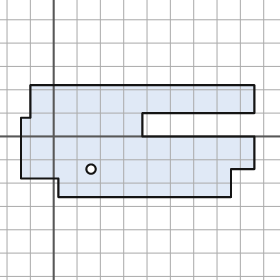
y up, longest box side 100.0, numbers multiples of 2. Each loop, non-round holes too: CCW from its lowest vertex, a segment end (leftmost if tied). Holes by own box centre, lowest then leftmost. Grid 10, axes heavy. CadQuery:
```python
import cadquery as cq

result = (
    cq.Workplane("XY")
    .moveTo(2.0, -26.0)
    .lineTo(76.0, -26.0)
    .lineTo(76.0, -14.0)
    .lineTo(86.0, -14.0)
    .lineTo(86.0, 0.0)
    .lineTo(38.0, 0.0)
    .lineTo(38.0, 10.0)
    .lineTo(86.0, 10.0)
    .lineTo(86.0, 22.0)
    .lineTo(-10.0, 22.0)
    .lineTo(-10.0, 8.0)
    .lineTo(-14.0, 8.0)
    .lineTo(-14.0, -18.0)
    .lineTo(2.0, -18.0)
    .close()
    .moveTo(16.0, -14.0)
    .circle(2.0)
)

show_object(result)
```